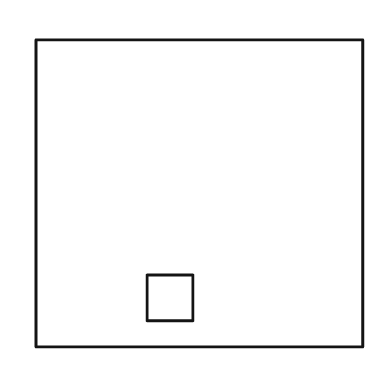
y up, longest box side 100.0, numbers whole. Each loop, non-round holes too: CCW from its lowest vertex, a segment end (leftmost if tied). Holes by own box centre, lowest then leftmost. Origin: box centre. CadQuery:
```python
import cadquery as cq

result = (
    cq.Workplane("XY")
    .moveTo(-50.0, -47.0)
    .lineTo(50.0, -47.0)
    .lineTo(50.0, 47.0)
    .lineTo(-50.0, 47.0)
    .close()
    .moveTo(-16.0, -39.0)
    .lineTo(-2.0, -39.0)
    .lineTo(-2.0, -25.0)
    .lineTo(-16.0, -25.0)
    .close()
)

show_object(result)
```